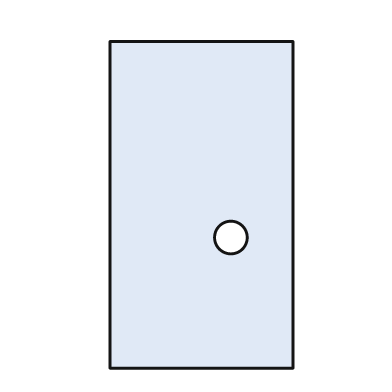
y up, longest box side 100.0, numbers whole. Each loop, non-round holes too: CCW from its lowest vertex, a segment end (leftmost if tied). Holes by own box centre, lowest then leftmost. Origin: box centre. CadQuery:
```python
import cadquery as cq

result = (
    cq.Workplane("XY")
    .moveTo(-28.0, -50.0)
    .lineTo(28.0, -50.0)
    .lineTo(28.0, 50.0)
    .lineTo(-28.0, 50.0)
    .close()
    .moveTo(9.0, -10.0)
    .circle(5.0)
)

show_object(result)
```